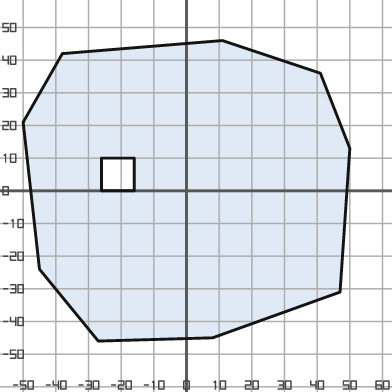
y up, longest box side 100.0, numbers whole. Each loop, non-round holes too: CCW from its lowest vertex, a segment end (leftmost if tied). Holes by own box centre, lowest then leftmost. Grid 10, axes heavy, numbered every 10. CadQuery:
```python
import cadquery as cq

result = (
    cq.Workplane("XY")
    .moveTo(-27.0, -46.0)
    .lineTo(8.0, -45.0)
    .lineTo(47.0, -31.0)
    .lineTo(50.0, 13.0)
    .lineTo(41.0, 36.0)
    .lineTo(11.0, 46.0)
    .lineTo(-38.0, 42.0)
    .lineTo(-50.0, 21.0)
    .lineTo(-45.0, -24.0)
    .close()
    .moveTo(-26.0, 0.0)
    .lineTo(-16.0, 0.0)
    .lineTo(-16.0, 10.0)
    .lineTo(-26.0, 10.0)
    .close()
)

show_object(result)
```